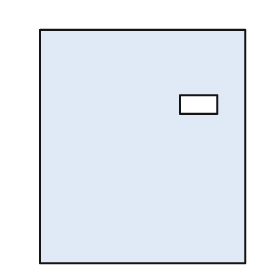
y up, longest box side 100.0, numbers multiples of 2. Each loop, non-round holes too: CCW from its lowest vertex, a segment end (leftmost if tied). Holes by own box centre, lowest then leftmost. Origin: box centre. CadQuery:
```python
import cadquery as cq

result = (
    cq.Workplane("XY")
    .moveTo(-44.0, -50.0)
    .lineTo(44.0, -50.0)
    .lineTo(44.0, 50.0)
    .lineTo(-44.0, 50.0)
    .close()
    .moveTo(16.0, 14.0)
    .lineTo(32.0, 14.0)
    .lineTo(32.0, 22.0)
    .lineTo(16.0, 22.0)
    .close()
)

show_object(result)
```